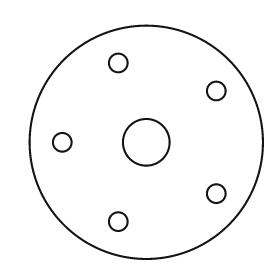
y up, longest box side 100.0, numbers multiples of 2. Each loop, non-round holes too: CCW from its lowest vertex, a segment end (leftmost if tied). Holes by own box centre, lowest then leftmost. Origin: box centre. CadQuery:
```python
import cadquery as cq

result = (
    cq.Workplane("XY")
    .moveTo(0.0, 0.0)
    .circle(50.0)
    .moveTo(-12.0, -34.0)
    .circle(4.0)
    .moveTo(30.0, -22.0)
    .circle(4.0)
    .moveTo(-36.0, 0.0)
    .circle(4.0)
    .moveTo(0.0, 0.0)
    .circle(10.0)
    .moveTo(30.0, 22.0)
    .circle(4.0)
    .moveTo(-12.0, 34.0)
    .circle(4.0)
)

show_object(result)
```